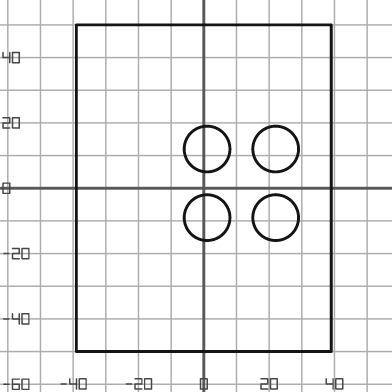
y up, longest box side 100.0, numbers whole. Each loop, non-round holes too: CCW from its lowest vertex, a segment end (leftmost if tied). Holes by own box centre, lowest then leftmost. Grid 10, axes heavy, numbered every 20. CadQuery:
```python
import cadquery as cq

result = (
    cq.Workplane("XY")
    .moveTo(-39.0, -50.0)
    .lineTo(39.0, -50.0)
    .lineTo(39.0, 50.0)
    .lineTo(-39.0, 50.0)
    .close()
    .moveTo(1.0, -9.0)
    .circle(7.0)
    .moveTo(22.0, -9.0)
    .circle(7.0)
    .moveTo(1.0, 12.0)
    .circle(7.0)
    .moveTo(22.0, 12.0)
    .circle(7.0)
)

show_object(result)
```